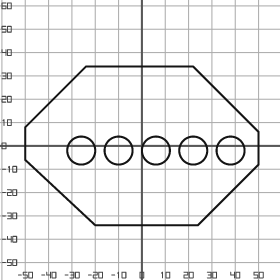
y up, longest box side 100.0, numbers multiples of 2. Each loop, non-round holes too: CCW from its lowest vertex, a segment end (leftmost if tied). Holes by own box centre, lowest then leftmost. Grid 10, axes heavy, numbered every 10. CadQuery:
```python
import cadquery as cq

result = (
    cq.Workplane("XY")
    .moveTo(-20.0, -34.0)
    .lineTo(24.0, -34.0)
    .lineTo(50.0, -8.0)
    .lineTo(50.0, 6.0)
    .lineTo(22.0, 34.0)
    .lineTo(-24.0, 34.0)
    .lineTo(-50.0, 8.0)
    .lineTo(-50.0, -6.0)
    .close()
    .moveTo(-26.0, -2.0)
    .circle(6.0)
    .moveTo(-10.0, -2.0)
    .circle(6.0)
    .moveTo(6.0, -2.0)
    .circle(6.0)
    .moveTo(22.0, -2.0)
    .circle(6.0)
    .moveTo(38.0, -2.0)
    .circle(6.0)
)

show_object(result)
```